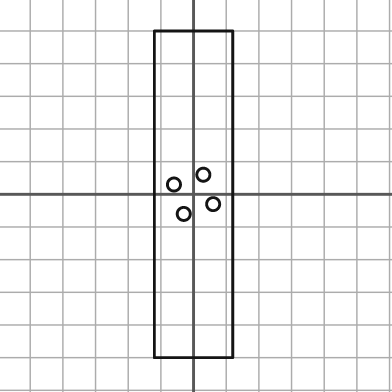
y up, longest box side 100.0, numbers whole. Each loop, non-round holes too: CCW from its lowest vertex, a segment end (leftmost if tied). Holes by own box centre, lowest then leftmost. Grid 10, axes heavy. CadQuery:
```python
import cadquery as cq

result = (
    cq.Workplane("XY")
    .moveTo(-12.0, -50.0)
    .lineTo(12.0, -50.0)
    .lineTo(12.0, 50.0)
    .lineTo(-12.0, 50.0)
    .close()
    .moveTo(-3.0, -6.0)
    .circle(2.0)
    .moveTo(6.0, -3.0)
    .circle(2.0)
    .moveTo(-6.0, 3.0)
    .circle(2.0)
    .moveTo(3.0, 6.0)
    .circle(2.0)
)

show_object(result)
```